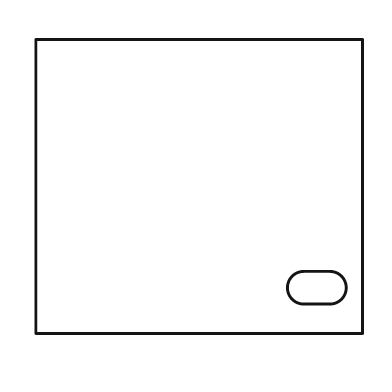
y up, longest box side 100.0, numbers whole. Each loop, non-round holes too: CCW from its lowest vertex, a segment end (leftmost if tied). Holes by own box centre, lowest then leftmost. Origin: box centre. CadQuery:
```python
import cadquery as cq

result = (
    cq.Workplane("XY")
    .moveTo(-50.0, -45.0)
    .lineTo(50.0, -45.0)
    .lineTo(50.0, 45.0)
    .lineTo(-50.0, 45.0)
    .close()
    .moveTo(32.0, -36.0)
    .lineTo(40.0, -36.0)
    .threePointArc((45.0, -31.0), (40.0, -26.0))
    .lineTo(32.0, -26.0)
    .threePointArc((27.0, -31.0), (32.0, -36.0))
    .close()
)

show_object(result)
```